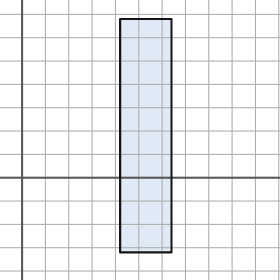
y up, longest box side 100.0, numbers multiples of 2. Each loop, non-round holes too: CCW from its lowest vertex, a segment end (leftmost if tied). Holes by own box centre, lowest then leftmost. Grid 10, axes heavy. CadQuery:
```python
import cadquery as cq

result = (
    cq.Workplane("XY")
    .moveTo(42.0, -32.0)
    .lineTo(64.0, -32.0)
    .lineTo(64.0, 68.0)
    .lineTo(42.0, 68.0)
    .close()
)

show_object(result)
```